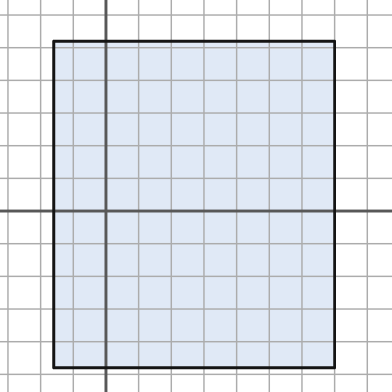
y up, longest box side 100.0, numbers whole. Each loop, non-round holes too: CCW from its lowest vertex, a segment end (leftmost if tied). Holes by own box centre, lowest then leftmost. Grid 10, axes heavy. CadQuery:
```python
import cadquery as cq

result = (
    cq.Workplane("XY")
    .moveTo(-16.0, -48.0)
    .lineTo(70.0, -48.0)
    .lineTo(70.0, 52.0)
    .lineTo(-16.0, 52.0)
    .close()
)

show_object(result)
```